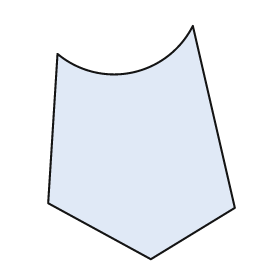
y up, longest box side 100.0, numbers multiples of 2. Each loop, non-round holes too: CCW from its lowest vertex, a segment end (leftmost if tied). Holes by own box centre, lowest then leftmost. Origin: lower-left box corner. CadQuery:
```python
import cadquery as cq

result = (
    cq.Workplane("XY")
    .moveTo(44.0, 0.0)
    .lineTo(80.0, 22.0)
    .lineTo(62.0, 100.0)
    .threePointArc((36.0, 80.0), (4.0, 88.0))
    .lineTo(0.0, 24.0)
    .close()
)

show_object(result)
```